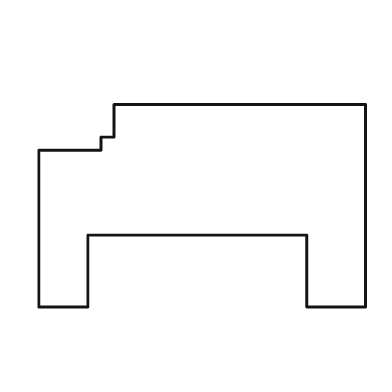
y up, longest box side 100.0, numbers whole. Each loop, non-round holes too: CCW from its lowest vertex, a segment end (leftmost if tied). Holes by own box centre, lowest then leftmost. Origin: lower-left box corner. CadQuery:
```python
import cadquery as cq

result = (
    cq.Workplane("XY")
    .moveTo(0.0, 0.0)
    .lineTo(15.0, 0.0)
    .lineTo(15.0, 22.0)
    .lineTo(82.0, 22.0)
    .lineTo(82.0, 0.0)
    .lineTo(100.0, 0.0)
    .lineTo(100.0, 62.0)
    .lineTo(23.0, 62.0)
    .lineTo(23.0, 52.0)
    .lineTo(19.0, 52.0)
    .lineTo(19.0, 48.0)
    .lineTo(0.0, 48.0)
    .close()
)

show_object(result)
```